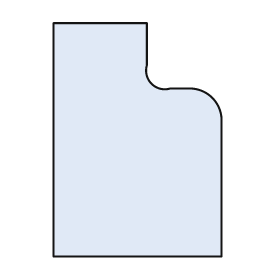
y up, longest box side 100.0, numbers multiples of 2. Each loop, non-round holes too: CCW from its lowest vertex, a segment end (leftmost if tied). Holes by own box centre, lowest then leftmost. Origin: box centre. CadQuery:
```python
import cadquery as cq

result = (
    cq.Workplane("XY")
    .moveTo(-36.0, -50.0)
    .lineTo(36.0, -50.0)
    .lineTo(36.0, 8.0)
    .threePointArc((32.0, 18.0), (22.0, 22.0))
    .lineTo(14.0, 22.0)
    .threePointArc((6.0, 24.0), (4.0, 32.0))
    .lineTo(4.0, 50.0)
    .lineTo(-36.0, 50.0)
    .close()
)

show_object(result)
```